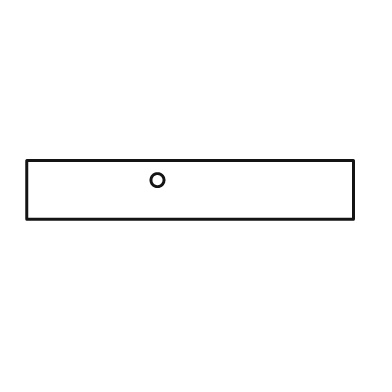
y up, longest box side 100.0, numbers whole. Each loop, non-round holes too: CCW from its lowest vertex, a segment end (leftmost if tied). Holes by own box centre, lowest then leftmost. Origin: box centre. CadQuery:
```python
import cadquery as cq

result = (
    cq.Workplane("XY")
    .moveTo(-50.0, -9.0)
    .lineTo(50.0, -9.0)
    .lineTo(50.0, 9.0)
    .lineTo(-50.0, 9.0)
    .close()
    .moveTo(-10.0, 3.0)
    .circle(2.0)
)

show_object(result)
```